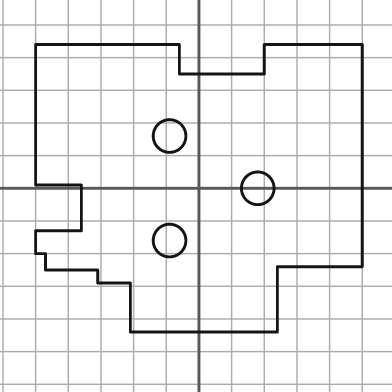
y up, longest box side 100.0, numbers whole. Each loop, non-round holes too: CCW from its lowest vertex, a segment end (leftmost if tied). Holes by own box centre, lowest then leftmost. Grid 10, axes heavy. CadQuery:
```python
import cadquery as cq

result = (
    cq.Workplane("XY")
    .moveTo(-21.0, -44.0)
    .lineTo(24.0, -44.0)
    .lineTo(24.0, -24.0)
    .lineTo(50.0, -24.0)
    .lineTo(50.0, 44.0)
    .lineTo(20.0, 44.0)
    .lineTo(20.0, 35.0)
    .lineTo(-6.0, 35.0)
    .lineTo(-6.0, 44.0)
    .lineTo(-50.0, 44.0)
    .lineTo(-50.0, 1.0)
    .lineTo(-36.0, 1.0)
    .lineTo(-36.0, -13.0)
    .lineTo(-50.0, -13.0)
    .lineTo(-50.0, -20.0)
    .lineTo(-47.0, -20.0)
    .lineTo(-47.0, -25.0)
    .lineTo(-31.0, -25.0)
    .lineTo(-31.0, -29.0)
    .lineTo(-21.0, -29.0)
    .close()
    .moveTo(-9.0, -16.0)
    .circle(5.0)
    .moveTo(18.0, 0.0)
    .circle(5.0)
    .moveTo(-9.0, 16.0)
    .circle(5.0)
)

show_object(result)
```